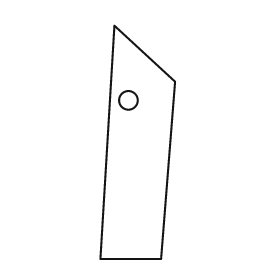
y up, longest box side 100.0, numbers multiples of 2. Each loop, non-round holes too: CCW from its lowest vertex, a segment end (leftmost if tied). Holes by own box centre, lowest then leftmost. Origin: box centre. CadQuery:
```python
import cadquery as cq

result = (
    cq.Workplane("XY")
    .moveTo(-16.0, -50.0)
    .lineTo(10.0, -50.0)
    .lineTo(16.0, 26.0)
    .lineTo(-10.0, 50.0)
    .close()
    .moveTo(-4.0, 18.0)
    .circle(4.0)
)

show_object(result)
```